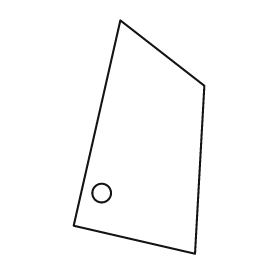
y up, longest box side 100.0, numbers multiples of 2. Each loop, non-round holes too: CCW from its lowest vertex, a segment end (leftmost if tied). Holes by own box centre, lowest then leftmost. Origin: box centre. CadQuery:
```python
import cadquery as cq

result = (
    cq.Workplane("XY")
    .moveTo(24.0, -50.0)
    .lineTo(28.0, 22.0)
    .lineTo(-8.0, 50.0)
    .lineTo(-28.0, -38.0)
    .close()
    .moveTo(-16.0, -24.0)
    .circle(4.0)
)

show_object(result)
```